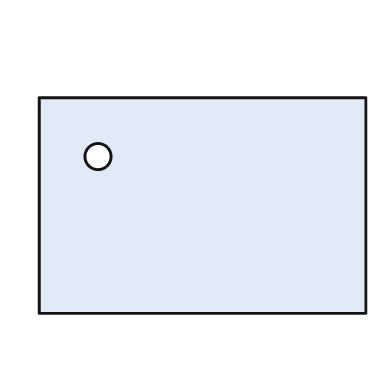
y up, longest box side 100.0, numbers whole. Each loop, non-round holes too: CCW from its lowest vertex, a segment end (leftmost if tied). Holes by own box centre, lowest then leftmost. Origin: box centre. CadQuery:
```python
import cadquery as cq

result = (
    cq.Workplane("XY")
    .moveTo(-50.0, -33.0)
    .lineTo(50.0, -33.0)
    .lineTo(50.0, 33.0)
    .lineTo(-50.0, 33.0)
    .close()
    .moveTo(-32.0, 15.0)
    .circle(4.0)
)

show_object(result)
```